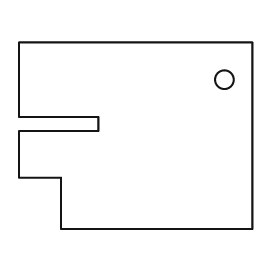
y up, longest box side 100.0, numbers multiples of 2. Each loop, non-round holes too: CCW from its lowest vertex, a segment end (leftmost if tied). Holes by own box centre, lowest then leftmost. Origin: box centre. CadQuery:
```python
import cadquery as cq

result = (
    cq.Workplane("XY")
    .moveTo(-32.0, -40.0)
    .lineTo(50.0, -40.0)
    .lineTo(50.0, 40.0)
    .lineTo(-50.0, 40.0)
    .lineTo(-50.0, 8.0)
    .lineTo(-16.0, 8.0)
    .lineTo(-16.0, 2.0)
    .lineTo(-50.0, 2.0)
    .lineTo(-50.0, -18.0)
    .lineTo(-32.0, -18.0)
    .close()
    .moveTo(38.0, 24.0)
    .circle(4.0)
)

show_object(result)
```